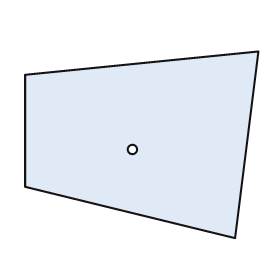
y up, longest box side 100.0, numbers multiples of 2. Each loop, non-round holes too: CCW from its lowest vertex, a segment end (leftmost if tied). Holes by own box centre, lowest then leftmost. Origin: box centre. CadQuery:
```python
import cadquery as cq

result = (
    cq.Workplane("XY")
    .moveTo(40.0, -40.0)
    .lineTo(50.0, 40.0)
    .lineTo(-50.0, 30.0)
    .lineTo(-50.0, -18.0)
    .close()
    .moveTo(-4.0, -2.0)
    .circle(2.0)
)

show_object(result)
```